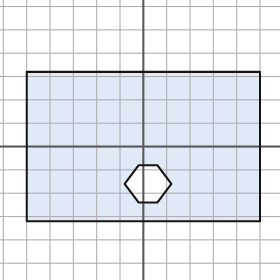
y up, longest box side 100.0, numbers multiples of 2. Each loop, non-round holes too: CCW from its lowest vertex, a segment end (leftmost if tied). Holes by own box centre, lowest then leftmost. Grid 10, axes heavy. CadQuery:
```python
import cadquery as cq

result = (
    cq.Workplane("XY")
    .moveTo(-50.0, -32.0)
    .lineTo(50.0, -32.0)
    .lineTo(50.0, 32.0)
    .lineTo(-50.0, 32.0)
    .close()
    .moveTo(-2.0, -24.0)
    .lineTo(6.0, -24.0)
    .lineTo(12.0, -16.0)
    .lineTo(6.0, -8.0)
    .lineTo(-2.0, -8.0)
    .lineTo(-8.0, -16.0)
    .close()
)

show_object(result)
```